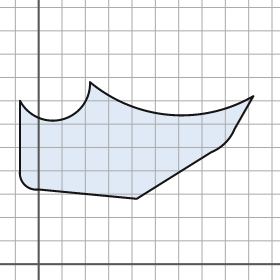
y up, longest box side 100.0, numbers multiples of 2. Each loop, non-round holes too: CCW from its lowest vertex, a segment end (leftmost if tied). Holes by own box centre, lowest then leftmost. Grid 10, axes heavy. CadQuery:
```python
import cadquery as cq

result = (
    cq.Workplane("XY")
    .moveTo(42.0, 28.0)
    .lineTo(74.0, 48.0)
    .threePointArc((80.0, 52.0), (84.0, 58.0))
    .lineTo(92.0, 72.0)
    .threePointArc((56.0, 64.0), (22.0, 78.0))
    .threePointArc((10.0, 62.0), (-8.0, 70.0))
    .lineTo(-8.0, 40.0)
    .threePointArc((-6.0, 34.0), (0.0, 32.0))
    .close()
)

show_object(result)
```